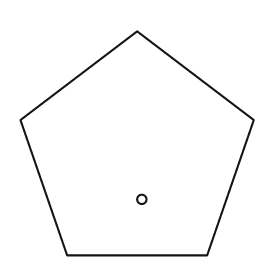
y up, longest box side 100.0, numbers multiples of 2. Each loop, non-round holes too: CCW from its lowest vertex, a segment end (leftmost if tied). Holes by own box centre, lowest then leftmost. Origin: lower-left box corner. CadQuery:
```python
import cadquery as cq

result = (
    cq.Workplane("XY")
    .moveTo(20.0, 0.0)
    .lineTo(80.0, 0.0)
    .lineTo(100.0, 58.0)
    .lineTo(50.0, 96.0)
    .lineTo(0.0, 58.0)
    .close()
    .moveTo(52.0, 24.0)
    .circle(2.0)
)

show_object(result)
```